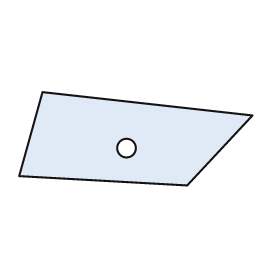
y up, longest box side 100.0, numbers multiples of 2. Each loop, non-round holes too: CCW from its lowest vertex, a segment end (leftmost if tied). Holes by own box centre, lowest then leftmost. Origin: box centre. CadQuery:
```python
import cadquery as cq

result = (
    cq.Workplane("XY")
    .moveTo(22.0, -20.0)
    .lineTo(50.0, 10.0)
    .lineTo(-40.0, 20.0)
    .lineTo(-50.0, -16.0)
    .close()
    .moveTo(-4.0, -4.0)
    .circle(4.0)
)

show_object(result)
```